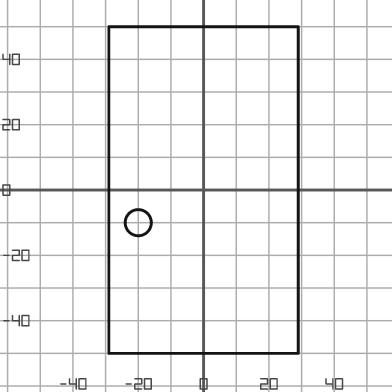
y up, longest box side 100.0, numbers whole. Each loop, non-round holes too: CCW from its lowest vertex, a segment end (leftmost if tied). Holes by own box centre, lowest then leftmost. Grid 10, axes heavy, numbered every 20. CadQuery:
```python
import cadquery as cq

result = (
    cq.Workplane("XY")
    .moveTo(-29.0, -50.0)
    .lineTo(29.0, -50.0)
    .lineTo(29.0, 50.0)
    .lineTo(-29.0, 50.0)
    .close()
    .moveTo(-20.0, -10.0)
    .circle(4.0)
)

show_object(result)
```